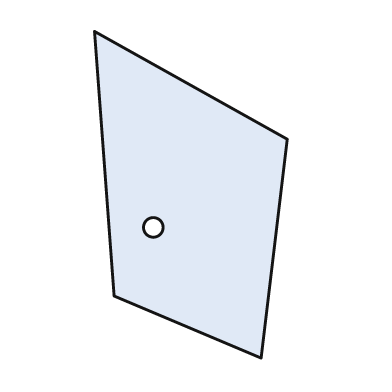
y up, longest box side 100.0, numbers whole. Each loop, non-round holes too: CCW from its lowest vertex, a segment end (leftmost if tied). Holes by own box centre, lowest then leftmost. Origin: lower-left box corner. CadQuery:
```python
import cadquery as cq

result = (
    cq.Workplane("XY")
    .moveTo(51.0, 0.0)
    .lineTo(59.0, 67.0)
    .lineTo(0.0, 100.0)
    .lineTo(6.0, 19.0)
    .close()
    .moveTo(18.0, 40.0)
    .circle(3.0)
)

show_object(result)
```